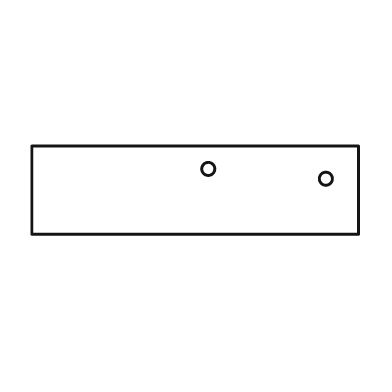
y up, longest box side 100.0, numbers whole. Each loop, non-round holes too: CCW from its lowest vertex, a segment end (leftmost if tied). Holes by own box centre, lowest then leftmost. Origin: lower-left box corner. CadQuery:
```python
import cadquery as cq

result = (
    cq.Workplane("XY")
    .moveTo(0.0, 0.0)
    .lineTo(100.0, 0.0)
    .lineTo(100.0, 27.0)
    .lineTo(0.0, 27.0)
    .close()
    .moveTo(90.0, 17.0)
    .circle(2.0)
    .moveTo(54.0, 20.0)
    .circle(2.0)
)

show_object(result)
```